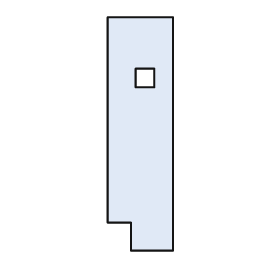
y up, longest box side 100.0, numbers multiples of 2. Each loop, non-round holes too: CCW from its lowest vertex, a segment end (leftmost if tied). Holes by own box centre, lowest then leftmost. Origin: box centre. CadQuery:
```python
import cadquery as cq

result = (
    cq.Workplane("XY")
    .moveTo(-4.0, -50.0)
    .lineTo(14.0, -50.0)
    .lineTo(14.0, 50.0)
    .lineTo(-14.0, 50.0)
    .lineTo(-14.0, -38.0)
    .lineTo(-4.0, -38.0)
    .close()
    .moveTo(-2.0, 20.0)
    .lineTo(6.0, 20.0)
    .lineTo(6.0, 28.0)
    .lineTo(-2.0, 28.0)
    .close()
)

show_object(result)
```